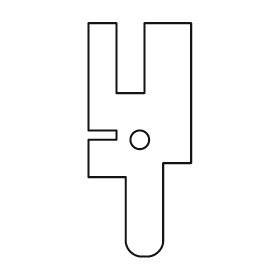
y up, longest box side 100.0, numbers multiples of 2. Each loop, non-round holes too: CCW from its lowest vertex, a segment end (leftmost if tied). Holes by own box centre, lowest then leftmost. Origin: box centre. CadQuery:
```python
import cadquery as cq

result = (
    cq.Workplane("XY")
    .moveTo(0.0, -50.0)
    .lineTo(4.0, -50.0)
    .threePointArc((8.0, -48.0), (10.0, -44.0))
    .lineTo(10.0, -10.0)
    .lineTo(22.0, -10.0)
    .lineTo(22.0, 50.0)
    .lineTo(2.0, 50.0)
    .lineTo(2.0, 20.0)
    .lineTo(-10.0, 20.0)
    .lineTo(-10.0, 50.0)
    .lineTo(-22.0, 50.0)
    .lineTo(-22.0, 4.0)
    .lineTo(-10.0, 4.0)
    .lineTo(-10.0, 0.0)
    .lineTo(-22.0, 0.0)
    .lineTo(-22.0, -16.0)
    .lineTo(-6.0, -16.0)
    .lineTo(-6.0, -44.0)
    .threePointArc((-4.0, -48.0), (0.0, -50.0))
    .close()
    .moveTo(0.0, 0.0)
    .circle(4.0)
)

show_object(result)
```